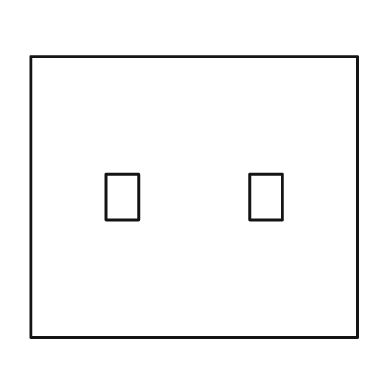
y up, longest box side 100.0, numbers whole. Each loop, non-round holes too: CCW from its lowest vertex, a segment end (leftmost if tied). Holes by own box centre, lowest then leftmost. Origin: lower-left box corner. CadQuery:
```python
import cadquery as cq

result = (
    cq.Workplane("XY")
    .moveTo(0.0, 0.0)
    .lineTo(100.0, 0.0)
    .lineTo(100.0, 86.0)
    .lineTo(0.0, 86.0)
    .close()
    .moveTo(23.0, 36.0)
    .lineTo(33.0, 36.0)
    .lineTo(33.0, 50.0)
    .lineTo(23.0, 50.0)
    .close()
    .moveTo(67.0, 36.0)
    .lineTo(77.0, 36.0)
    .lineTo(77.0, 50.0)
    .lineTo(67.0, 50.0)
    .close()
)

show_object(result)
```